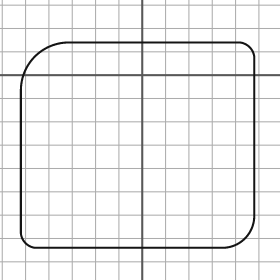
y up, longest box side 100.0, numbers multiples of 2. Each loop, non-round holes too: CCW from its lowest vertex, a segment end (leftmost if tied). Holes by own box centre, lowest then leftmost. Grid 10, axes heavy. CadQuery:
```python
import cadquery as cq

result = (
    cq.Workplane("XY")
    .moveTo(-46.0, -74.0)
    .lineTo(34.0, -74.0)
    .threePointArc((44.0, -70.0), (48.0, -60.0))
    .lineTo(48.0, 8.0)
    .threePointArc((46.0, 12.0), (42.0, 14.0))
    .lineTo(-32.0, 14.0)
    .threePointArc((-46.0, 8.0), (-52.0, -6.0))
    .lineTo(-52.0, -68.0)
    .threePointArc((-50.0, -72.0), (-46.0, -74.0))
    .close()
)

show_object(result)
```